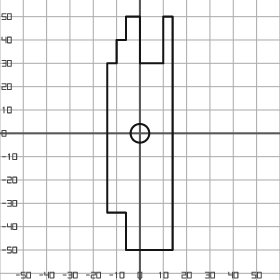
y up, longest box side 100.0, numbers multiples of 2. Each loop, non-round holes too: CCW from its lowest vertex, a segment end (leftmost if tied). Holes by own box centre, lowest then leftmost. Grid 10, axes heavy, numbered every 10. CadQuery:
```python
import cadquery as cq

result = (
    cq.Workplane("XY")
    .moveTo(-6.0, -50.0)
    .lineTo(14.0, -50.0)
    .lineTo(14.0, 50.0)
    .lineTo(10.0, 50.0)
    .lineTo(10.0, 30.0)
    .lineTo(0.0, 30.0)
    .lineTo(0.0, 50.0)
    .lineTo(-6.0, 50.0)
    .lineTo(-6.0, 40.0)
    .lineTo(-10.0, 40.0)
    .lineTo(-10.0, 30.0)
    .lineTo(-14.0, 30.0)
    .lineTo(-14.0, -34.0)
    .lineTo(-6.0, -34.0)
    .close()
    .moveTo(0.0, 0.0)
    .circle(4.0)
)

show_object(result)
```